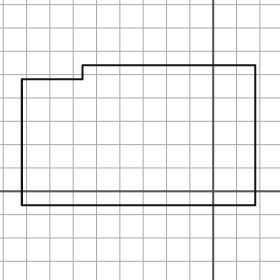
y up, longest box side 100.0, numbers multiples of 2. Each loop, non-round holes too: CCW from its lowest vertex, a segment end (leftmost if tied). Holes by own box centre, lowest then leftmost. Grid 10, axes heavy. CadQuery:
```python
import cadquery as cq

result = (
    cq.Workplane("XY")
    .moveTo(-82.0, -6.0)
    .lineTo(18.0, -6.0)
    .lineTo(18.0, 54.0)
    .lineTo(-56.0, 54.0)
    .lineTo(-56.0, 48.0)
    .lineTo(-82.0, 48.0)
    .close()
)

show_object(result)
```